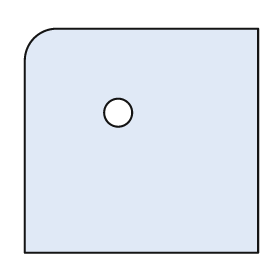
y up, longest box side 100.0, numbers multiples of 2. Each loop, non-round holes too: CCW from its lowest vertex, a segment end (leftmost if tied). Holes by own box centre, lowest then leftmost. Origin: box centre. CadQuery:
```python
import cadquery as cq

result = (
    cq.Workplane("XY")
    .moveTo(-50.0, -48.0)
    .lineTo(50.0, -48.0)
    .lineTo(50.0, 48.0)
    .lineTo(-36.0, 48.0)
    .threePointArc((-46.0, 44.0), (-50.0, 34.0))
    .close()
    .moveTo(-10.0, 12.0)
    .circle(6.0)
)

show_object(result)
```